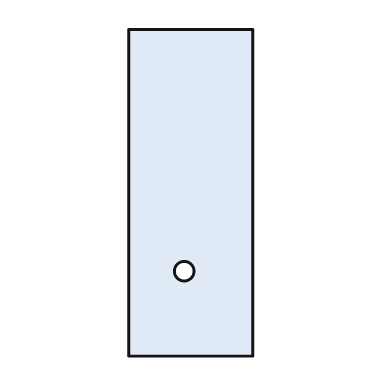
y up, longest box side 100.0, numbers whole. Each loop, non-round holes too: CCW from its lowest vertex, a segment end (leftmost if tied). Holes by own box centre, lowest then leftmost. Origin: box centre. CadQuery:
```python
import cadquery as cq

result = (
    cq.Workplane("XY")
    .moveTo(-19.0, -50.0)
    .lineTo(19.0, -50.0)
    .lineTo(19.0, 50.0)
    .lineTo(-19.0, 50.0)
    .close()
    .moveTo(-2.0, -24.0)
    .circle(3.0)
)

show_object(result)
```